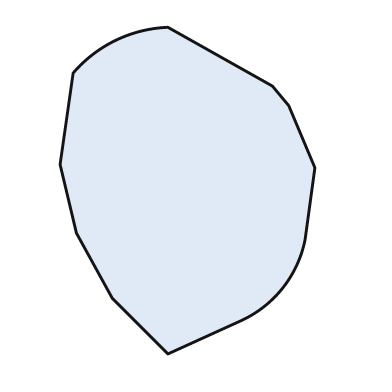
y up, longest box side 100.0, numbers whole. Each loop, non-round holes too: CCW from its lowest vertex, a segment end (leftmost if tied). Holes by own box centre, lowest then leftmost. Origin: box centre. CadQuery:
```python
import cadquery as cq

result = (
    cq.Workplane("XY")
    .moveTo(-6.0, -50.0)
    .lineTo(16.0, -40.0)
    .threePointArc((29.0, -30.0), (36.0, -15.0))
    .lineTo(39.0, 7.0)
    .lineTo(31.0, 26.0)
    .lineTo(26.0, 32.0)
    .lineTo(-6.0, 50.0)
    .threePointArc((-22.0, 46.0), (-35.0, 36.0))
    .lineTo(-39.0, 8.0)
    .lineTo(-34.0, -13.0)
    .lineTo(-23.0, -33.0)
    .close()
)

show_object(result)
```